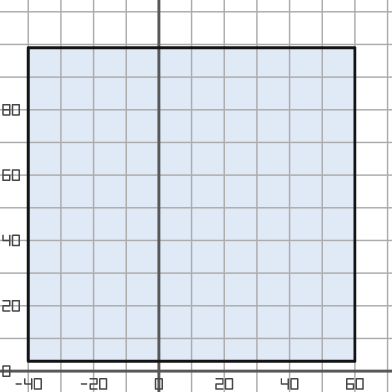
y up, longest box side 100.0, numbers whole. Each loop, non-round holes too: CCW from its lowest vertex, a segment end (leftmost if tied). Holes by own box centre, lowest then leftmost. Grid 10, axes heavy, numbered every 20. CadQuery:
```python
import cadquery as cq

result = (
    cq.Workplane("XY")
    .moveTo(-40.0, 3.0)
    .lineTo(60.0, 3.0)
    .lineTo(60.0, 99.0)
    .lineTo(-40.0, 99.0)
    .close()
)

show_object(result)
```